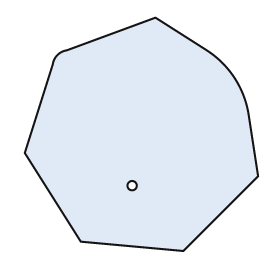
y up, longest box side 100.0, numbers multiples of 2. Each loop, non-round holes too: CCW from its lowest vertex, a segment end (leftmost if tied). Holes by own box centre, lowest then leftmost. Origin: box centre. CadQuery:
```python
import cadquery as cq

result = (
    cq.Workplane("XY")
    .moveTo(18.0, -50.0)
    .lineTo(50.0, -18.0)
    .lineTo(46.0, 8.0)
    .threePointArc((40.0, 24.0), (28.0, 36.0))
    .lineTo(6.0, 50.0)
    .lineTo(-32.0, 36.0)
    .threePointArc((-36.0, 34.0), (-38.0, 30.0))
    .lineTo(-50.0, -8.0)
    .lineTo(-26.0, -46.0)
    .close()
    .moveTo(-4.0, -22.0)
    .circle(2.0)
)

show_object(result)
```